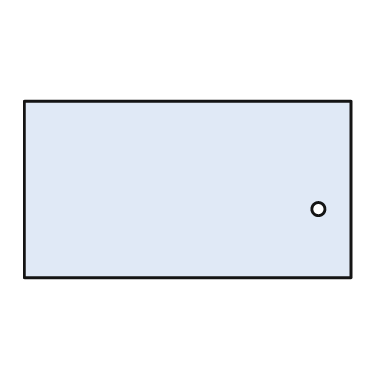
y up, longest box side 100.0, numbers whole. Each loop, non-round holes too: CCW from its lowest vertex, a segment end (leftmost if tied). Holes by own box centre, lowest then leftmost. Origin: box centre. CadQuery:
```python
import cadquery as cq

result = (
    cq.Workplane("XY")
    .moveTo(-50.0, -27.0)
    .lineTo(50.0, -27.0)
    .lineTo(50.0, 27.0)
    .lineTo(-50.0, 27.0)
    .close()
    .moveTo(40.0, -6.0)
    .circle(2.0)
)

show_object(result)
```